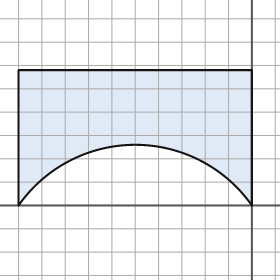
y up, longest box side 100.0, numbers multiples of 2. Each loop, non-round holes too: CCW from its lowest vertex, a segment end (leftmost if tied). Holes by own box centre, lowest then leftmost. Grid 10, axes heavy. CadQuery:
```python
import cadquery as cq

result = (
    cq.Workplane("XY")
    .moveTo(-100.0, 0.0)
    .threePointArc((-50.0, 26.0), (0.0, 0.0))
    .lineTo(0.0, 58.0)
    .lineTo(-100.0, 58.0)
    .close()
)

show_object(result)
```